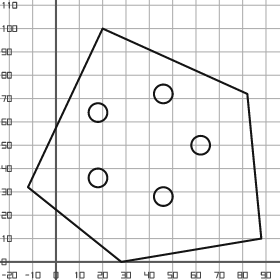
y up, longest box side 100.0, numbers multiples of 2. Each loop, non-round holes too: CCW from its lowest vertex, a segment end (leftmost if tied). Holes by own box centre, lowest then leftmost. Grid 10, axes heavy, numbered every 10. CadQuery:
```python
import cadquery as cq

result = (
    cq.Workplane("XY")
    .moveTo(28.0, 0.0)
    .lineTo(88.0, 10.0)
    .lineTo(82.0, 72.0)
    .lineTo(20.0, 100.0)
    .lineTo(-12.0, 32.0)
    .close()
    .moveTo(46.0, 28.0)
    .circle(4.0)
    .moveTo(18.0, 36.0)
    .circle(4.0)
    .moveTo(62.0, 50.0)
    .circle(4.0)
    .moveTo(18.0, 64.0)
    .circle(4.0)
    .moveTo(46.0, 72.0)
    .circle(4.0)
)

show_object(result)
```